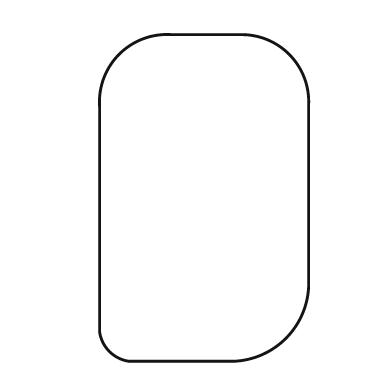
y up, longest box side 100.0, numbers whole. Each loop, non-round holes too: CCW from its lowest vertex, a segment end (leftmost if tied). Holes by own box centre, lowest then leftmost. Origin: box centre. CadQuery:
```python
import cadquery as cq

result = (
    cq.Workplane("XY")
    .moveTo(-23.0, -50.0)
    .lineTo(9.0, -50.0)
    .threePointArc((25.0, -43.0), (32.0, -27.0))
    .lineTo(32.0, 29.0)
    .threePointArc((26.0, 44.0), (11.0, 50.0))
    .lineTo(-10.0, 50.0)
    .threePointArc((-26.0, 44.0), (-32.0, 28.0))
    .lineTo(-32.0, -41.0)
    .threePointArc((-29.0, -47.0), (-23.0, -50.0))
    .close()
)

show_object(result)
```